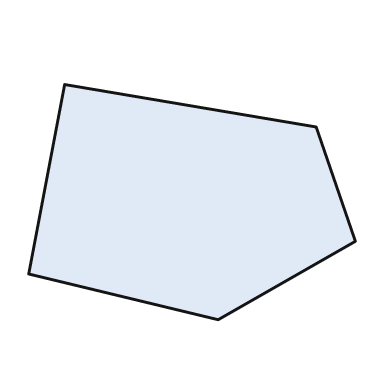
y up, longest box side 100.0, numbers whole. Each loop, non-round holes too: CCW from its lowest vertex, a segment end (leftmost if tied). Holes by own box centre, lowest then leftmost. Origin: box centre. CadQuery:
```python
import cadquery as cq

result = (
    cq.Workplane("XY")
    .moveTo(8.0, -36.0)
    .lineTo(50.0, -12.0)
    .lineTo(38.0, 23.0)
    .lineTo(-39.0, 36.0)
    .lineTo(-50.0, -22.0)
    .close()
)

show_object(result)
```